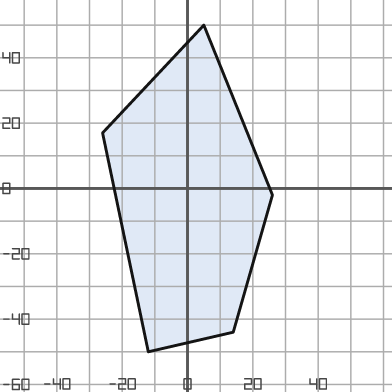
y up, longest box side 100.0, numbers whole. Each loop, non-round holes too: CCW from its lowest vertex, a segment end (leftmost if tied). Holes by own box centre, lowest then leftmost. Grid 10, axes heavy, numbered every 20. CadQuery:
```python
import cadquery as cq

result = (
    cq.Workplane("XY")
    .moveTo(-12.0, -50.0)
    .lineTo(14.0, -44.0)
    .lineTo(26.0, -2.0)
    .lineTo(5.0, 50.0)
    .lineTo(-26.0, 17.0)
    .close()
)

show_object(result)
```